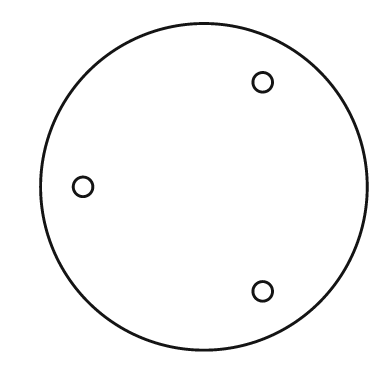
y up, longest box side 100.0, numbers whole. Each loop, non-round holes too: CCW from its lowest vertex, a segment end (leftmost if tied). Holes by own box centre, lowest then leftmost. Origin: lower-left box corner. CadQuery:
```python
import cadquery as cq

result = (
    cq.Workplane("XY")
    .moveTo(50.0, 50.0)
    .circle(50.0)
    .moveTo(68.0, 18.0)
    .circle(3.0)
    .moveTo(13.0, 50.0)
    .circle(3.0)
    .moveTo(68.0, 82.0)
    .circle(3.0)
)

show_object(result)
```